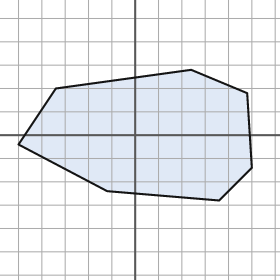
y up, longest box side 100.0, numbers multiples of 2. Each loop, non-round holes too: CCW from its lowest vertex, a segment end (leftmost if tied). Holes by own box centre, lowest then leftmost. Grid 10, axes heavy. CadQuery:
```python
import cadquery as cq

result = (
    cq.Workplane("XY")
    .moveTo(36.0, -28.0)
    .lineTo(50.0, -14.0)
    .lineTo(48.0, 18.0)
    .lineTo(24.0, 28.0)
    .lineTo(-34.0, 20.0)
    .lineTo(-50.0, -4.0)
    .lineTo(-12.0, -24.0)
    .close()
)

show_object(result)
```